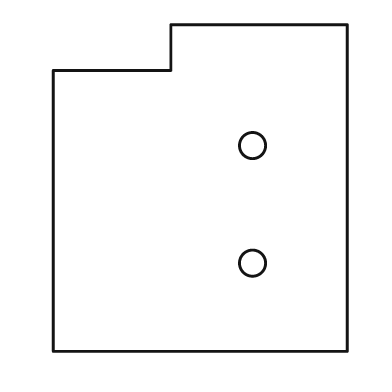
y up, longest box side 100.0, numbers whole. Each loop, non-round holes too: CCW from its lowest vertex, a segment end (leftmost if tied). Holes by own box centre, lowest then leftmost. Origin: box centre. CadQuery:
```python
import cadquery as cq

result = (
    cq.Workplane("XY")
    .moveTo(-45.0, -50.0)
    .lineTo(45.0, -50.0)
    .lineTo(45.0, 50.0)
    .lineTo(-9.0, 50.0)
    .lineTo(-9.0, 36.0)
    .lineTo(-45.0, 36.0)
    .close()
    .moveTo(16.0, -23.0)
    .circle(4.0)
    .moveTo(16.0, 13.0)
    .circle(4.0)
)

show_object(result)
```